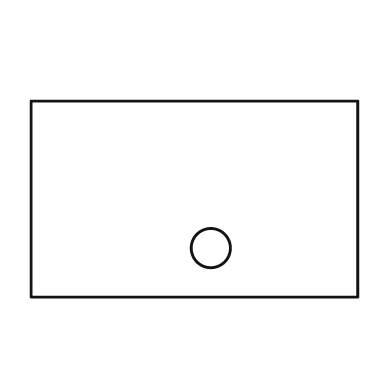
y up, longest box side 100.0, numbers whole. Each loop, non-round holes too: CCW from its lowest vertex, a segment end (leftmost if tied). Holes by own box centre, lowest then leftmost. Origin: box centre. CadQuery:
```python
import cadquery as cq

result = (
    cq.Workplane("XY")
    .moveTo(-50.0, -30.0)
    .lineTo(50.0, -30.0)
    .lineTo(50.0, 30.0)
    .lineTo(-50.0, 30.0)
    .close()
    .moveTo(5.0, -15.0)
    .circle(6.0)
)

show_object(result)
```